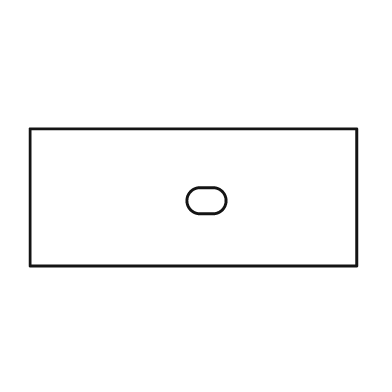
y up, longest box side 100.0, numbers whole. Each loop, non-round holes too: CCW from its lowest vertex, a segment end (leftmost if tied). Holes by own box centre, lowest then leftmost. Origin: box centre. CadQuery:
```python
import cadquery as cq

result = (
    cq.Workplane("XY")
    .moveTo(-50.0, -21.0)
    .lineTo(50.0, -21.0)
    .lineTo(50.0, 21.0)
    .lineTo(-50.0, 21.0)
    .close()
    .moveTo(2.0, -5.0)
    .lineTo(6.0, -5.0)
    .threePointArc((10.0, -1.0), (6.0, 3.0))
    .lineTo(2.0, 3.0)
    .threePointArc((-2.0, -1.0), (2.0, -5.0))
    .close()
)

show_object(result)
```